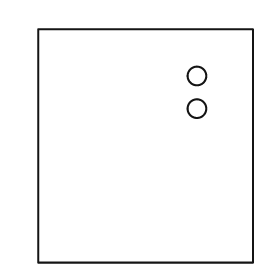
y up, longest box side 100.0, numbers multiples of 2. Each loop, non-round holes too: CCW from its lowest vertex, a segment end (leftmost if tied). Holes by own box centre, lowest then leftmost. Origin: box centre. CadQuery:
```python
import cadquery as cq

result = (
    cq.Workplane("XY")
    .moveTo(-46.0, -50.0)
    .lineTo(46.0, -50.0)
    .lineTo(46.0, 50.0)
    .lineTo(-46.0, 50.0)
    .close()
    .moveTo(22.0, 16.0)
    .circle(4.0)
    .moveTo(22.0, 30.0)
    .circle(4.0)
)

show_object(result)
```